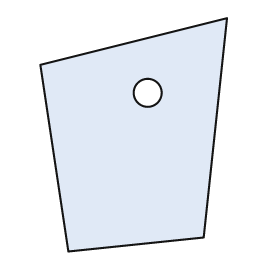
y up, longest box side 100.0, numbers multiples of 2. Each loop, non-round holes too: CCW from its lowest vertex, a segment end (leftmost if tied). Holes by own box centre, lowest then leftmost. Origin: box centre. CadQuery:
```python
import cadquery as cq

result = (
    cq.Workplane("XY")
    .moveTo(-28.0, -50.0)
    .lineTo(30.0, -44.0)
    .lineTo(40.0, 50.0)
    .lineTo(-40.0, 30.0)
    .close()
    .moveTo(6.0, 18.0)
    .circle(6.0)
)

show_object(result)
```